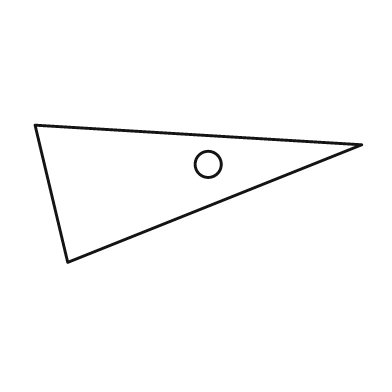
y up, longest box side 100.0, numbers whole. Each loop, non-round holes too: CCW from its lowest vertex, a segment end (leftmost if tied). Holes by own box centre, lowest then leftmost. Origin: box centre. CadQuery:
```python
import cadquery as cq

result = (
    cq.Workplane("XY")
    .moveTo(-40.0, -21.0)
    .lineTo(50.0, 15.0)
    .lineTo(-50.0, 21.0)
    .close()
    .moveTo(3.0, 9.0)
    .circle(4.0)
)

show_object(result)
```